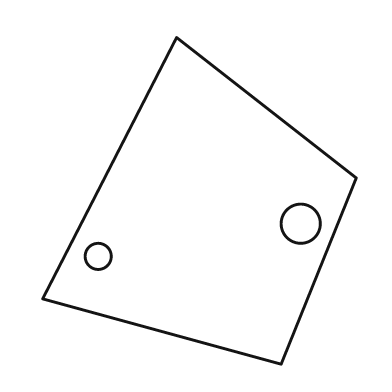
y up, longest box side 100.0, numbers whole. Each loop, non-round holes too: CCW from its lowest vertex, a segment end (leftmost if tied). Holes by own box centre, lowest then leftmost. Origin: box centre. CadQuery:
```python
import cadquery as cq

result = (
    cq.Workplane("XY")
    .moveTo(25.0, -50.0)
    .lineTo(48.0, 7.0)
    .lineTo(-7.0, 50.0)
    .lineTo(-48.0, -30.0)
    .close()
    .moveTo(-31.0, -17.0)
    .circle(4.0)
    .moveTo(31.0, -7.0)
    .circle(6.0)
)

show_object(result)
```